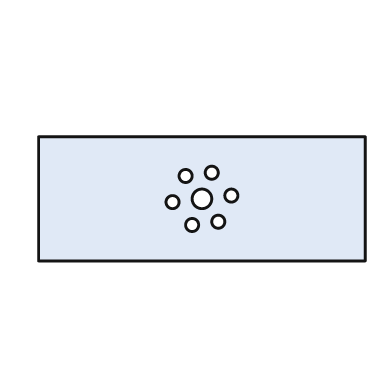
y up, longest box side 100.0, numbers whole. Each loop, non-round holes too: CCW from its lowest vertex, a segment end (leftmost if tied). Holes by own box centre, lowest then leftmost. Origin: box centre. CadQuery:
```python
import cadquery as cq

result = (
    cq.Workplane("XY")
    .moveTo(-50.0, -19.0)
    .lineTo(50.0, -19.0)
    .lineTo(50.0, 19.0)
    .lineTo(-50.0, 19.0)
    .close()
    .moveTo(-3.0, -8.0)
    .circle(2.0)
    .moveTo(5.0, -7.0)
    .circle(2.0)
    .moveTo(-9.0, -1.0)
    .circle(2.0)
    .moveTo(0.0, 0.0)
    .circle(3.0)
    .moveTo(9.0, 1.0)
    .circle(2.0)
    .moveTo(-5.0, 7.0)
    .circle(2.0)
    .moveTo(3.0, 8.0)
    .circle(2.0)
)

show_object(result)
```